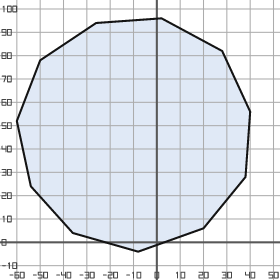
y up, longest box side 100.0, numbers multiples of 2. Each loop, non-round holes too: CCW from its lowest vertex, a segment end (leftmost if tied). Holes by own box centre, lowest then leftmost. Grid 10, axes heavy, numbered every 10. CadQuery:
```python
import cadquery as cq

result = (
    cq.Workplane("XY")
    .moveTo(-8.0, -4.0)
    .lineTo(20.0, 6.0)
    .lineTo(38.0, 28.0)
    .lineTo(40.0, 56.0)
    .lineTo(28.0, 82.0)
    .lineTo(2.0, 96.0)
    .lineTo(-26.0, 94.0)
    .lineTo(-50.0, 78.0)
    .lineTo(-60.0, 52.0)
    .lineTo(-54.0, 24.0)
    .lineTo(-36.0, 4.0)
    .close()
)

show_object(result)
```